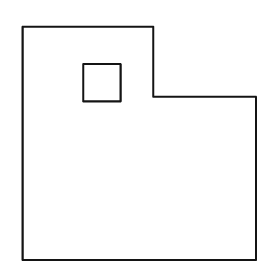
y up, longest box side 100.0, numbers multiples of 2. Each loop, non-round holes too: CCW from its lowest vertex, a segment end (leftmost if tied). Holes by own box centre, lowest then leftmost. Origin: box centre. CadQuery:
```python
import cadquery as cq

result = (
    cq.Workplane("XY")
    .moveTo(-50.0, -50.0)
    .lineTo(50.0, -50.0)
    .lineTo(50.0, 20.0)
    .lineTo(6.0, 20.0)
    .lineTo(6.0, 50.0)
    .lineTo(-50.0, 50.0)
    .close()
    .moveTo(-24.0, 18.0)
    .lineTo(-8.0, 18.0)
    .lineTo(-8.0, 34.0)
    .lineTo(-24.0, 34.0)
    .close()
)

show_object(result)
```